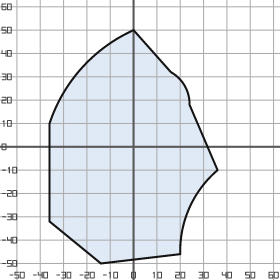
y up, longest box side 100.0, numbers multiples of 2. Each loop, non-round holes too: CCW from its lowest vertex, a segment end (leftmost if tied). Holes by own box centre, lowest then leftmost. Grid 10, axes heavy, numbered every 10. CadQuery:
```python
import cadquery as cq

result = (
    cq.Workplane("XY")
    .moveTo(-14.0, -50.0)
    .lineTo(20.0, -46.0)
    .threePointArc((24.0, -26.0), (36.0, -10.0))
    .lineTo(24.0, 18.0)
    .threePointArc((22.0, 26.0), (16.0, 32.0))
    .lineTo(0.0, 50.0)
    .threePointArc((-22.0, 34.0), (-36.0, 10.0))
    .lineTo(-36.0, -32.0)
    .close()
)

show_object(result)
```